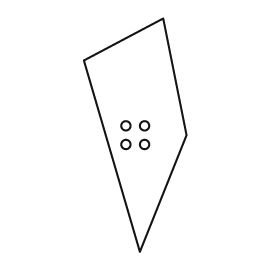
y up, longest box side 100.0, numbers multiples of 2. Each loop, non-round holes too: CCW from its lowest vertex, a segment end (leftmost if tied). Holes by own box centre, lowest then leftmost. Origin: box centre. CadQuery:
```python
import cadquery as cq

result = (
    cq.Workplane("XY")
    .moveTo(2.0, -50.0)
    .lineTo(22.0, 0.0)
    .lineTo(12.0, 50.0)
    .lineTo(-22.0, 32.0)
    .close()
    .moveTo(-4.0, -4.0)
    .circle(2.0)
    .moveTo(4.0, -4.0)
    .circle(2.0)
    .moveTo(-4.0, 4.0)
    .circle(2.0)
    .moveTo(4.0, 4.0)
    .circle(2.0)
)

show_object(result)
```